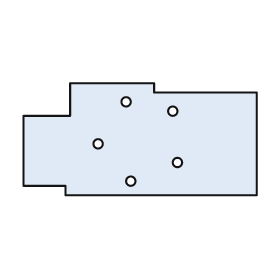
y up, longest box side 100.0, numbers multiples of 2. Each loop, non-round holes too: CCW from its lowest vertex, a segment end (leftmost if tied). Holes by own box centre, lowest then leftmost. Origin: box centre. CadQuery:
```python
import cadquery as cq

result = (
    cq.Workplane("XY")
    .moveTo(-32.0, -24.0)
    .lineTo(50.0, -24.0)
    .lineTo(50.0, 20.0)
    .lineTo(6.0, 20.0)
    .lineTo(6.0, 24.0)
    .lineTo(-30.0, 24.0)
    .lineTo(-30.0, 10.0)
    .lineTo(-50.0, 10.0)
    .lineTo(-50.0, -20.0)
    .lineTo(-32.0, -20.0)
    .close()
    .moveTo(-4.0, -18.0)
    .circle(2.0)
    .moveTo(16.0, -10.0)
    .circle(2.0)
    .moveTo(-18.0, -2.0)
    .circle(2.0)
    .moveTo(14.0, 12.0)
    .circle(2.0)
    .moveTo(-6.0, 16.0)
    .circle(2.0)
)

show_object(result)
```